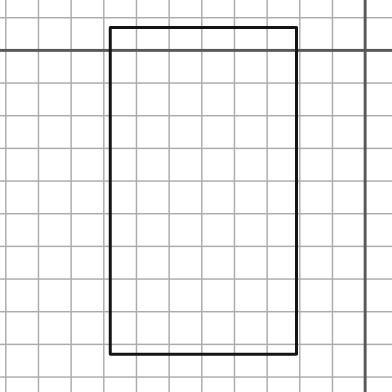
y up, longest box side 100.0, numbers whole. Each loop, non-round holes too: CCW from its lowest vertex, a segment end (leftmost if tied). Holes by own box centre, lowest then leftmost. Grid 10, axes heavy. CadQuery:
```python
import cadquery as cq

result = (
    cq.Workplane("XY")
    .moveTo(-78.0, -93.0)
    .lineTo(-21.0, -93.0)
    .lineTo(-21.0, 7.0)
    .lineTo(-78.0, 7.0)
    .close()
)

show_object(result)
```